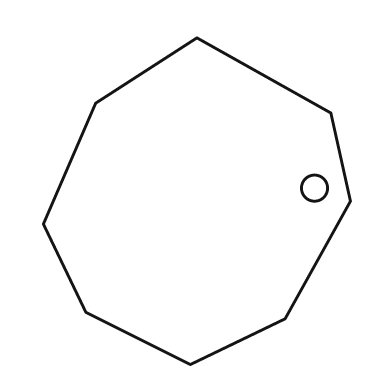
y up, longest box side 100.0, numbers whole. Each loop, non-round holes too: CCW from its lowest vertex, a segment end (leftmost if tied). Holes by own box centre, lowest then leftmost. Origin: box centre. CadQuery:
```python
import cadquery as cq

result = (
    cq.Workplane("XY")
    .moveTo(-2.0, -50.0)
    .lineTo(27.0, -36.0)
    .lineTo(47.0, 0.0)
    .lineTo(41.0, 27.0)
    .lineTo(0.0, 50.0)
    .lineTo(-31.0, 30.0)
    .lineTo(-47.0, -7.0)
    .lineTo(-34.0, -34.0)
    .close()
    .moveTo(36.0, 4.0)
    .circle(4.0)
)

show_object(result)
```